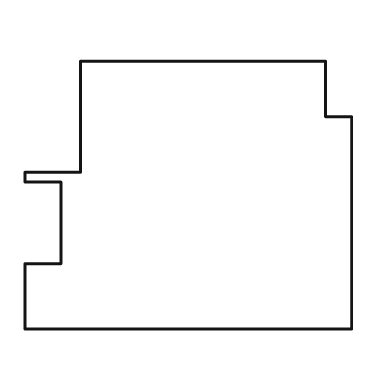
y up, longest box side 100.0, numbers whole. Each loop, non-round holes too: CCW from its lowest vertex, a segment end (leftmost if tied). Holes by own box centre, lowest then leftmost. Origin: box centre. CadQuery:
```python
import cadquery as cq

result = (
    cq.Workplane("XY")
    .moveTo(-50.0, -41.0)
    .lineTo(50.0, -41.0)
    .lineTo(50.0, 24.0)
    .lineTo(42.0, 24.0)
    .lineTo(42.0, 41.0)
    .lineTo(-33.0, 41.0)
    .lineTo(-33.0, 7.0)
    .lineTo(-50.0, 7.0)
    .lineTo(-50.0, 4.0)
    .lineTo(-39.0, 4.0)
    .lineTo(-39.0, -21.0)
    .lineTo(-50.0, -21.0)
    .close()
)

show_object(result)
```